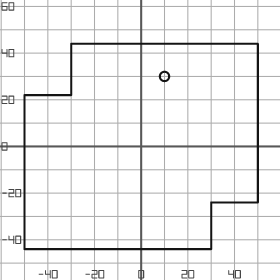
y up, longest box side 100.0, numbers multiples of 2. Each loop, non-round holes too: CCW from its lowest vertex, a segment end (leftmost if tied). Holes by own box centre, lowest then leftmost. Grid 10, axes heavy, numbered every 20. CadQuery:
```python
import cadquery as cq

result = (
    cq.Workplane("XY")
    .moveTo(-50.0, -44.0)
    .lineTo(30.0, -44.0)
    .lineTo(30.0, -24.0)
    .lineTo(50.0, -24.0)
    .lineTo(50.0, 44.0)
    .lineTo(-30.0, 44.0)
    .lineTo(-30.0, 22.0)
    .lineTo(-50.0, 22.0)
    .close()
    .moveTo(10.0, 30.0)
    .circle(2.0)
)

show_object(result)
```